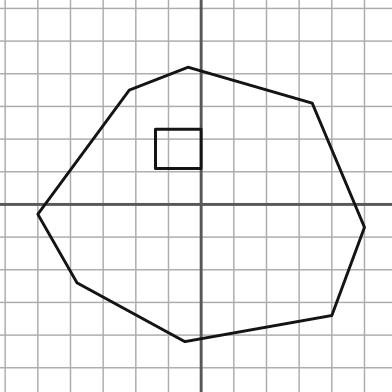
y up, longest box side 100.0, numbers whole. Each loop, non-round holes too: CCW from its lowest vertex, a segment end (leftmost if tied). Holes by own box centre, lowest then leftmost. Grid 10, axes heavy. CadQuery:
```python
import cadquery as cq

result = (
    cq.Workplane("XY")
    .moveTo(-5.0, -42.0)
    .lineTo(40.0, -34.0)
    .lineTo(50.0, -7.0)
    .lineTo(34.0, 31.0)
    .lineTo(-4.0, 42.0)
    .lineTo(-22.0, 35.0)
    .lineTo(-50.0, -3.0)
    .lineTo(-38.0, -24.0)
    .close()
    .moveTo(-14.0, 11.0)
    .lineTo(0.0, 11.0)
    .lineTo(0.0, 23.0)
    .lineTo(-14.0, 23.0)
    .close()
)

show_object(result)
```